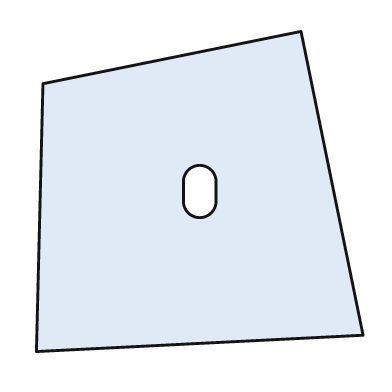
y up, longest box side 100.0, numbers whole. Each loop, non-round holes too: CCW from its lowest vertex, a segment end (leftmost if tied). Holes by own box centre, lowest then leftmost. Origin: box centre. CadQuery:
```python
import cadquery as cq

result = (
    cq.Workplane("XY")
    .moveTo(-50.0, -49.0)
    .lineTo(50.0, -44.0)
    .lineTo(31.0, 49.0)
    .lineTo(-48.0, 33.0)
    .close()
    .moveTo(-5.0, -3.0)
    .threePointArc((0.0, -8.0), (5.0, -3.0))
    .lineTo(5.0, 3.0)
    .threePointArc((0.0, 8.0), (-5.0, 3.0))
    .close()
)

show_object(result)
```